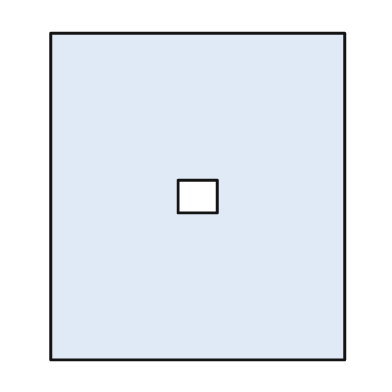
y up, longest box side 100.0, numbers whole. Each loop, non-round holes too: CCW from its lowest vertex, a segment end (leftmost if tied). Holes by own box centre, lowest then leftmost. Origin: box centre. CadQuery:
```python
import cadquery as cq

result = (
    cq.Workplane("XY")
    .moveTo(-45.0, -50.0)
    .lineTo(45.0, -50.0)
    .lineTo(45.0, 50.0)
    .lineTo(-45.0, 50.0)
    .close()
    .moveTo(-6.0, -5.0)
    .lineTo(6.0, -5.0)
    .lineTo(6.0, 5.0)
    .lineTo(-6.0, 5.0)
    .close()
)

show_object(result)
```